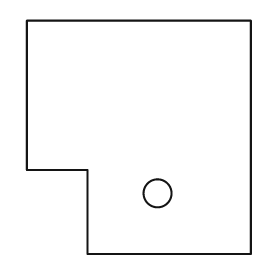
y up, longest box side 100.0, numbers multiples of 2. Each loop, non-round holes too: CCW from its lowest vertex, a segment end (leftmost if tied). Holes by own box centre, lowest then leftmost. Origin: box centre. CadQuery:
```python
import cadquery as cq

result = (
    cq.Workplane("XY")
    .moveTo(-22.0, -50.0)
    .lineTo(48.0, -50.0)
    .lineTo(48.0, 50.0)
    .lineTo(-48.0, 50.0)
    .lineTo(-48.0, -14.0)
    .lineTo(-22.0, -14.0)
    .close()
    .moveTo(8.0, -24.0)
    .circle(6.0)
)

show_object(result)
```